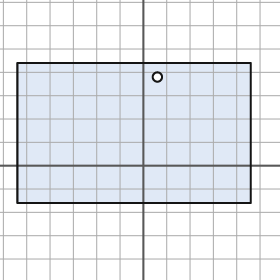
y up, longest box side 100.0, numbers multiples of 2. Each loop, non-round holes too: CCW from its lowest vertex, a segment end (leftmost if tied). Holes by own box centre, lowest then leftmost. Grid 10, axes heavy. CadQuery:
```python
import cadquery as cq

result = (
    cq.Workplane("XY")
    .moveTo(-54.0, -16.0)
    .lineTo(46.0, -16.0)
    .lineTo(46.0, 44.0)
    .lineTo(-54.0, 44.0)
    .close()
    .moveTo(6.0, 38.0)
    .circle(2.0)
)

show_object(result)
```